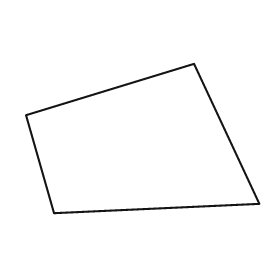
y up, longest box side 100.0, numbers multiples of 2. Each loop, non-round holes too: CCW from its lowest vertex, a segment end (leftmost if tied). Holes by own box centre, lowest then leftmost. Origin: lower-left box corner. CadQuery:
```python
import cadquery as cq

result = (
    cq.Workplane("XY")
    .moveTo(12.0, 0.0)
    .lineTo(100.0, 4.0)
    .lineTo(72.0, 64.0)
    .lineTo(0.0, 42.0)
    .close()
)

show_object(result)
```